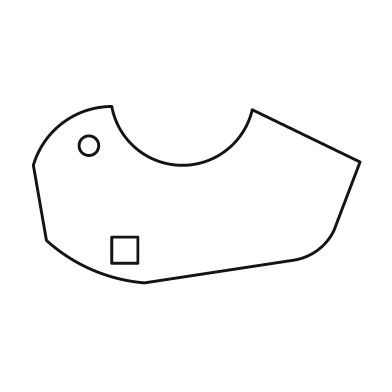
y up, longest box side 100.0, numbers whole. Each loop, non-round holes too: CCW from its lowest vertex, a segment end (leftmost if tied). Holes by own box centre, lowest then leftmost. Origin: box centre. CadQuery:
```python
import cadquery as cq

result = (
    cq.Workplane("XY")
    .moveTo(-16.0, -27.0)
    .lineTo(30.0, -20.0)
    .threePointArc((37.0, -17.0), (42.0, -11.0))
    .lineTo(50.0, 10.0)
    .lineTo(17.0, 26.0)
    .threePointArc((-5.0, 9.0), (-26.0, 27.0))
    .threePointArc((-41.0, 22.0), (-50.0, 9.0))
    .lineTo(-46.0, -14.0)
    .threePointArc((-32.0, -23.0), (-16.0, -27.0))
    .close()
    .moveTo(-26.0, -21.0)
    .lineTo(-18.0, -21.0)
    .lineTo(-18.0, -13.0)
    .lineTo(-26.0, -13.0)
    .close()
    .moveTo(-33.0, 15.0)
    .circle(3.0)
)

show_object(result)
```